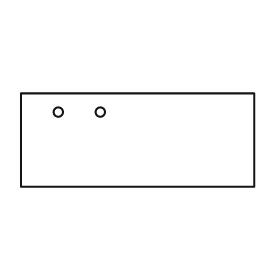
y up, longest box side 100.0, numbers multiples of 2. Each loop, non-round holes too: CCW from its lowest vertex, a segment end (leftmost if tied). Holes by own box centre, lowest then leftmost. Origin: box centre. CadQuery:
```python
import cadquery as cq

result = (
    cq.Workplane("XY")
    .moveTo(-50.0, -20.0)
    .lineTo(50.0, -20.0)
    .lineTo(50.0, 20.0)
    .lineTo(-50.0, 20.0)
    .close()
    .moveTo(-34.0, 12.0)
    .circle(2.0)
    .moveTo(-16.0, 12.0)
    .circle(2.0)
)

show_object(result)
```